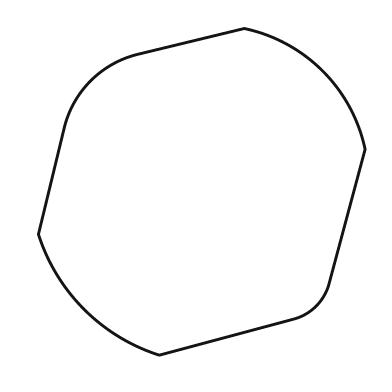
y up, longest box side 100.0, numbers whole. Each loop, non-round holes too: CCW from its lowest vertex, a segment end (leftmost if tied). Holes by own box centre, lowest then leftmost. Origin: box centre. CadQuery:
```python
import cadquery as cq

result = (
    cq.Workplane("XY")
    .moveTo(-13.0, -50.0)
    .lineTo(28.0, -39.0)
    .threePointArc((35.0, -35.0), (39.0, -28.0))
    .lineTo(50.0, 13.0)
    .threePointArc((37.0, 37.0), (13.0, 50.0))
    .lineTo(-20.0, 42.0)
    .threePointArc((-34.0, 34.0), (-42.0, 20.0))
    .lineTo(-50.0, -13.0)
    .threePointArc((-36.0, -36.0), (-13.0, -50.0))
    .close()
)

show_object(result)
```